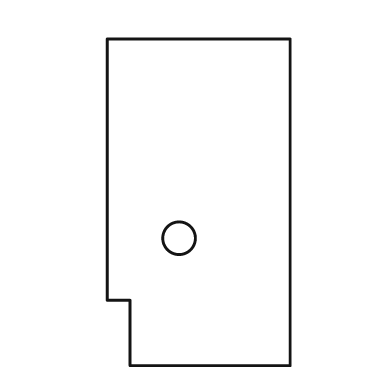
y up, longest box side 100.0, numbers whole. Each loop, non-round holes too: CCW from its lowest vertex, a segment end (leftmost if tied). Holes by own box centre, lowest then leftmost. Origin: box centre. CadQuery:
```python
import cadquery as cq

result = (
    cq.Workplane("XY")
    .moveTo(-21.0, -50.0)
    .lineTo(28.0, -50.0)
    .lineTo(28.0, 50.0)
    .lineTo(-28.0, 50.0)
    .lineTo(-28.0, -30.0)
    .lineTo(-21.0, -30.0)
    .close()
    .moveTo(-6.0, -11.0)
    .circle(5.0)
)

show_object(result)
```